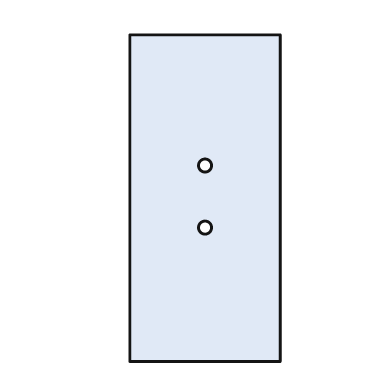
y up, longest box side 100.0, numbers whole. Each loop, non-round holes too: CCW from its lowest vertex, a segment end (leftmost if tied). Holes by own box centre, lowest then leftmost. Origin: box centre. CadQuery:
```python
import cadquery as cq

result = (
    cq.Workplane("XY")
    .moveTo(-23.0, -50.0)
    .lineTo(23.0, -50.0)
    .lineTo(23.0, 50.0)
    .lineTo(-23.0, 50.0)
    .close()
    .moveTo(0.0, -9.0)
    .circle(2.0)
    .moveTo(0.0, 10.0)
    .circle(2.0)
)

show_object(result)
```